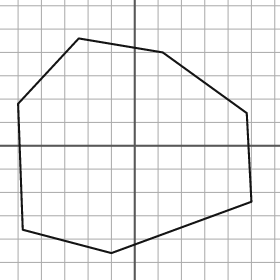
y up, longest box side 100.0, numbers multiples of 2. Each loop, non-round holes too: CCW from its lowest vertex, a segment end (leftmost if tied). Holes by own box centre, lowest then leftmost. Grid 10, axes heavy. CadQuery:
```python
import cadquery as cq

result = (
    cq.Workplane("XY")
    .moveTo(-10.0, -46.0)
    .lineTo(50.0, -24.0)
    .lineTo(48.0, 14.0)
    .lineTo(12.0, 40.0)
    .lineTo(-24.0, 46.0)
    .lineTo(-50.0, 18.0)
    .lineTo(-48.0, -36.0)
    .close()
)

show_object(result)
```